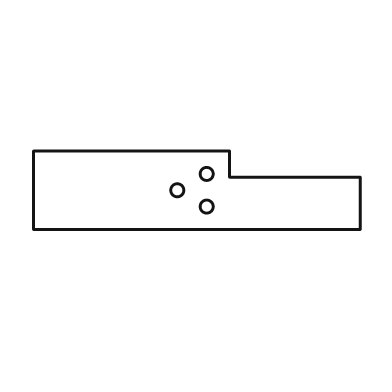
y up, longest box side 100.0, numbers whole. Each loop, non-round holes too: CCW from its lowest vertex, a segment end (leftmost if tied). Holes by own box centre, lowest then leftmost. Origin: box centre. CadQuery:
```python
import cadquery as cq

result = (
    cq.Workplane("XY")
    .moveTo(-50.0, -12.0)
    .lineTo(50.0, -12.0)
    .lineTo(50.0, 4.0)
    .lineTo(10.0, 4.0)
    .lineTo(10.0, 12.0)
    .lineTo(-50.0, 12.0)
    .close()
    .moveTo(3.0, -5.0)
    .circle(2.0)
    .moveTo(-6.0, 0.0)
    .circle(2.0)
    .moveTo(3.0, 5.0)
    .circle(2.0)
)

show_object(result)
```